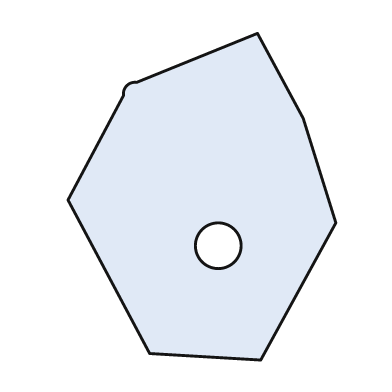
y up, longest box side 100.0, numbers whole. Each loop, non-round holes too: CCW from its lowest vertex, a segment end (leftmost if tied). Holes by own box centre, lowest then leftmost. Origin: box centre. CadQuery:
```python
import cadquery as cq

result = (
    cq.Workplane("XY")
    .moveTo(18.0, -50.0)
    .lineTo(41.0, -8.0)
    .lineTo(31.0, 24.0)
    .lineTo(17.0, 50.0)
    .lineTo(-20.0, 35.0)
    .threePointArc((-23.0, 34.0), (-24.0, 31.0))
    .lineTo(-41.0, -1.0)
    .lineTo(-16.0, -48.0)
    .close()
    .moveTo(5.0, -15.0)
    .circle(7.0)
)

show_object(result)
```